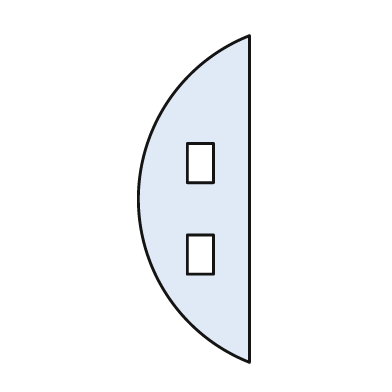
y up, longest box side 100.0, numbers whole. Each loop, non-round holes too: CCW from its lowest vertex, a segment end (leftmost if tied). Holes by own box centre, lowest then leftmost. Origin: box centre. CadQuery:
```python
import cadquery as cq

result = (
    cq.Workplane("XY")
    .moveTo(17.0, -50.0)
    .lineTo(17.0, 50.0)
    .threePointArc((-17.0, 0.0), (17.0, -50.0))
    .close()
    .moveTo(-2.0, -23.0)
    .lineTo(6.0, -23.0)
    .lineTo(6.0, -11.0)
    .lineTo(-2.0, -11.0)
    .close()
    .moveTo(-2.0, 5.0)
    .lineTo(6.0, 5.0)
    .lineTo(6.0, 17.0)
    .lineTo(-2.0, 17.0)
    .close()
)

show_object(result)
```